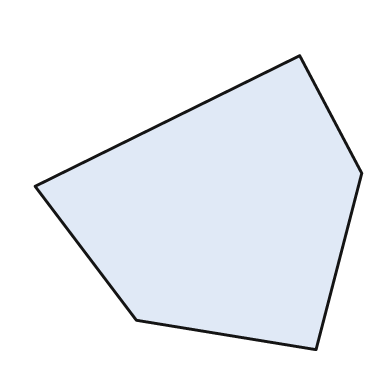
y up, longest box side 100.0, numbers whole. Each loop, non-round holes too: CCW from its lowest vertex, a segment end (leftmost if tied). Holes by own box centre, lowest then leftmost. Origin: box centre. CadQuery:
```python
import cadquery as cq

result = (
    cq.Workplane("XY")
    .moveTo(36.0, -45.0)
    .lineTo(50.0, 9.0)
    .lineTo(31.0, 45.0)
    .lineTo(-50.0, 5.0)
    .lineTo(-19.0, -36.0)
    .close()
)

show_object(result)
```